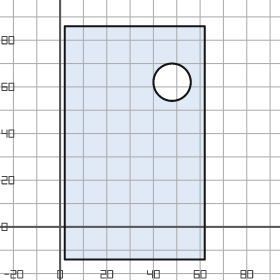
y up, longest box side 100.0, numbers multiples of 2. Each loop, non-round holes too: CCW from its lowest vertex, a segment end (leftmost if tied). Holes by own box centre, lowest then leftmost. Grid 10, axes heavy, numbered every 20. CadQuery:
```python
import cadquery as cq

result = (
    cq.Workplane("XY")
    .moveTo(2.0, -14.0)
    .lineTo(62.0, -14.0)
    .lineTo(62.0, 86.0)
    .lineTo(2.0, 86.0)
    .close()
    .moveTo(48.0, 62.0)
    .circle(8.0)
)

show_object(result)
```